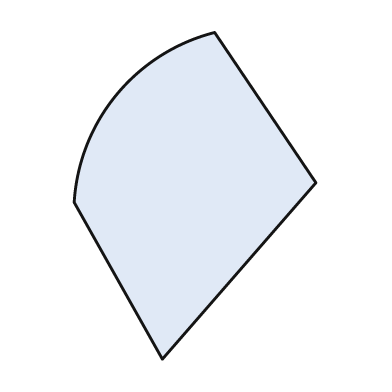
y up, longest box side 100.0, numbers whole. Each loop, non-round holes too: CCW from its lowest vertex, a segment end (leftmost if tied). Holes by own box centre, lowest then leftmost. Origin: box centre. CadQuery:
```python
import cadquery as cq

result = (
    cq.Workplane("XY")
    .moveTo(-10.0, -50.0)
    .lineTo(37.0, 4.0)
    .lineTo(6.0, 50.0)
    .threePointArc((-24.0, 31.0), (-37.0, -2.0))
    .close()
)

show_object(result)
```